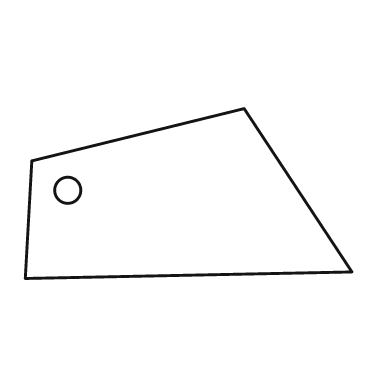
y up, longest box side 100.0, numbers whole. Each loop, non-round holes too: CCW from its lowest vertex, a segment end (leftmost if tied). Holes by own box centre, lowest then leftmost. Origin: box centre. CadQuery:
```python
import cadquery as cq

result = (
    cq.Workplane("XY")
    .moveTo(-50.0, -26.0)
    .lineTo(50.0, -24.0)
    .lineTo(17.0, 26.0)
    .lineTo(-48.0, 10.0)
    .close()
    .moveTo(-37.0, 1.0)
    .circle(4.0)
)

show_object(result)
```